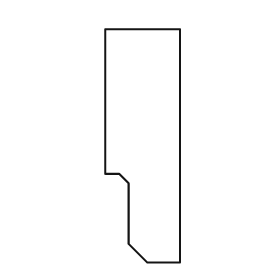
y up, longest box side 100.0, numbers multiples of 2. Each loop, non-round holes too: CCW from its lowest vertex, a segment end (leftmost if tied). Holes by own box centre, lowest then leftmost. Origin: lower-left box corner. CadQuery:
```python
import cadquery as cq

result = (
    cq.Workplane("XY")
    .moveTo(18.0, 0.0)
    .lineTo(32.0, 0.0)
    .lineTo(32.0, 100.0)
    .lineTo(0.0, 100.0)
    .lineTo(0.0, 38.0)
    .lineTo(6.0, 38.0)
    .lineTo(10.0, 34.0)
    .lineTo(10.0, 8.0)
    .close()
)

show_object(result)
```